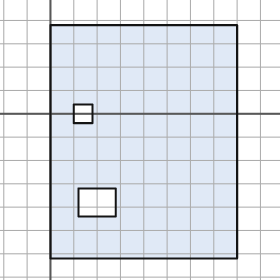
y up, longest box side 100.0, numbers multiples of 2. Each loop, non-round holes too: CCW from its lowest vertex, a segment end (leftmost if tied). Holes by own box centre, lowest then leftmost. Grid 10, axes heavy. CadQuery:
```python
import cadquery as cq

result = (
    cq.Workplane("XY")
    .moveTo(0.0, -62.0)
    .lineTo(80.0, -62.0)
    .lineTo(80.0, 38.0)
    .lineTo(0.0, 38.0)
    .close()
    .moveTo(12.0, -44.0)
    .lineTo(28.0, -44.0)
    .lineTo(28.0, -32.0)
    .lineTo(12.0, -32.0)
    .close()
    .moveTo(10.0, -4.0)
    .lineTo(18.0, -4.0)
    .lineTo(18.0, 4.0)
    .lineTo(10.0, 4.0)
    .close()
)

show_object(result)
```